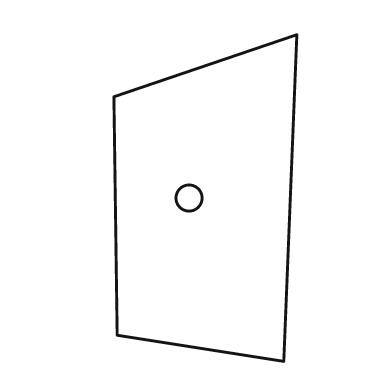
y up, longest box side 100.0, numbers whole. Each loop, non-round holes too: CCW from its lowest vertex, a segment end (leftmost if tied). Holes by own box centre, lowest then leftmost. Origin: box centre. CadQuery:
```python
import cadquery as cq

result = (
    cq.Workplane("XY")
    .moveTo(24.0, -50.0)
    .lineTo(28.0, 50.0)
    .lineTo(-28.0, 31.0)
    .lineTo(-27.0, -42.0)
    .close()
    .moveTo(-5.0, 0.0)
    .circle(4.0)
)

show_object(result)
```